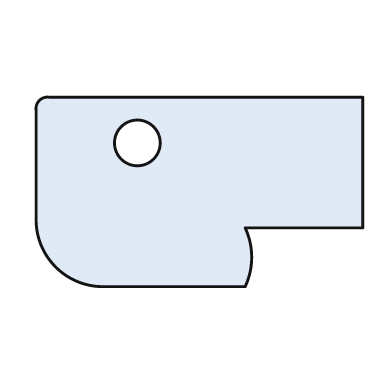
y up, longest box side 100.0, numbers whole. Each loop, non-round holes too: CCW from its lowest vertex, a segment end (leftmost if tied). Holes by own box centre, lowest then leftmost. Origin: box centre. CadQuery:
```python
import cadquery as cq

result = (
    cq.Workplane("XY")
    .moveTo(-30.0, -29.0)
    .lineTo(14.0, -29.0)
    .threePointArc((16.0, -20.0), (14.0, -11.0))
    .lineTo(50.0, -11.0)
    .lineTo(50.0, 29.0)
    .lineTo(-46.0, 29.0)
    .threePointArc((-49.0, 28.0), (-50.0, 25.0))
    .lineTo(-50.0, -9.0)
    .threePointArc((-44.0, -23.0), (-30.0, -29.0))
    .close()
    .moveTo(-19.0, 15.0)
    .circle(7.0)
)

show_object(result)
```